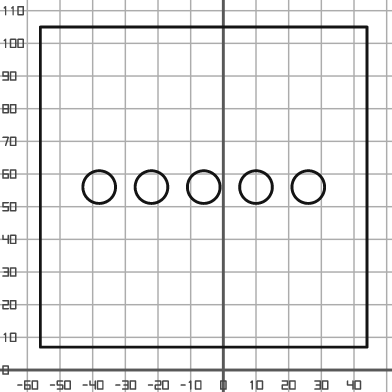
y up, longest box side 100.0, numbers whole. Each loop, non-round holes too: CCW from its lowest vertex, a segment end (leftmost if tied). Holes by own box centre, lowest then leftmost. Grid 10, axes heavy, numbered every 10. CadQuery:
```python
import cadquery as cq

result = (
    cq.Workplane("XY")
    .moveTo(-56.0, 7.0)
    .lineTo(44.0, 7.0)
    .lineTo(44.0, 105.0)
    .lineTo(-56.0, 105.0)
    .close()
    .moveTo(-38.0, 56.0)
    .circle(5.0)
    .moveTo(-22.0, 56.0)
    .circle(5.0)
    .moveTo(-6.0, 56.0)
    .circle(5.0)
    .moveTo(10.0, 56.0)
    .circle(5.0)
    .moveTo(26.0, 56.0)
    .circle(5.0)
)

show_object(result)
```